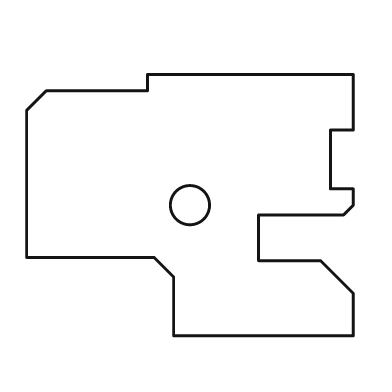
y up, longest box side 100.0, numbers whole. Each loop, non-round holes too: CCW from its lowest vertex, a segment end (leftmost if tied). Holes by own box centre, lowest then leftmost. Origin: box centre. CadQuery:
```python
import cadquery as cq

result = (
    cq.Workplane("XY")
    .moveTo(-5.0, -40.0)
    .lineTo(50.0, -40.0)
    .lineTo(50.0, -27.0)
    .lineTo(40.0, -17.0)
    .lineTo(21.0, -17.0)
    .lineTo(21.0, -3.0)
    .lineTo(47.0, -3.0)
    .lineTo(50.0, 0.0)
    .lineTo(50.0, 5.0)
    .lineTo(43.0, 5.0)
    .lineTo(43.0, 23.0)
    .lineTo(50.0, 23.0)
    .lineTo(50.0, 40.0)
    .lineTo(-13.0, 40.0)
    .lineTo(-13.0, 35.0)
    .lineTo(-44.0, 35.0)
    .lineTo(-50.0, 29.0)
    .lineTo(-50.0, -16.0)
    .lineTo(-11.0, -16.0)
    .lineTo(-5.0, -22.0)
    .close()
    .moveTo(0.0, 0.0)
    .circle(6.0)
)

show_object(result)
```